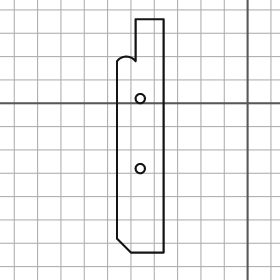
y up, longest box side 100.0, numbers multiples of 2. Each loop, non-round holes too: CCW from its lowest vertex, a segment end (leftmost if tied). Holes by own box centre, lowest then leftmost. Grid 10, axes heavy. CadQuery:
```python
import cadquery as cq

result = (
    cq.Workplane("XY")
    .moveTo(-50.0, -64.0)
    .lineTo(-36.0, -64.0)
    .lineTo(-36.0, 36.0)
    .lineTo(-48.0, 36.0)
    .lineTo(-48.0, 18.0)
    .threePointArc((-52.0, 20.0), (-56.0, 18.0))
    .lineTo(-56.0, -58.0)
    .close()
    .moveTo(-46.0, -28.0)
    .circle(2.0)
    .moveTo(-46.0, 2.0)
    .circle(2.0)
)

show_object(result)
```